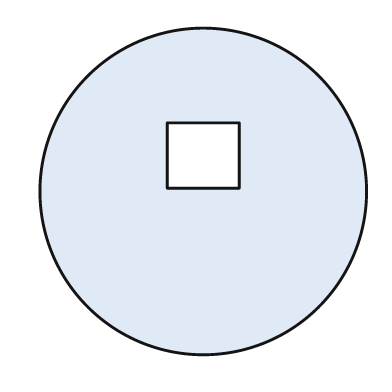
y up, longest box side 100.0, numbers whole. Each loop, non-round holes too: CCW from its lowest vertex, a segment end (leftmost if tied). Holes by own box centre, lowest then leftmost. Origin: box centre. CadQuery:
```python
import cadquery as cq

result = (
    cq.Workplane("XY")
    .moveTo(0.0, 0.0)
    .circle(50.0)
    .moveTo(-11.0, 1.0)
    .lineTo(11.0, 1.0)
    .lineTo(11.0, 21.0)
    .lineTo(-11.0, 21.0)
    .close()
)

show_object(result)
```